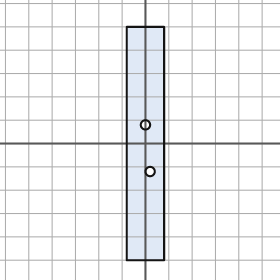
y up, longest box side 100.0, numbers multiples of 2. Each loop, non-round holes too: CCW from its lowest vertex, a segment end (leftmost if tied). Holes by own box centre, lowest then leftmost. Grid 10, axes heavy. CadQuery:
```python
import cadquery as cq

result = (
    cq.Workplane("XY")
    .moveTo(-8.0, -50.0)
    .lineTo(8.0, -50.0)
    .lineTo(8.0, 50.0)
    .lineTo(-8.0, 50.0)
    .close()
    .moveTo(2.0, -12.0)
    .circle(2.0)
    .moveTo(0.0, 8.0)
    .circle(2.0)
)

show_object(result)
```